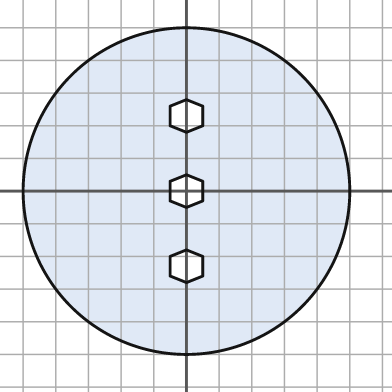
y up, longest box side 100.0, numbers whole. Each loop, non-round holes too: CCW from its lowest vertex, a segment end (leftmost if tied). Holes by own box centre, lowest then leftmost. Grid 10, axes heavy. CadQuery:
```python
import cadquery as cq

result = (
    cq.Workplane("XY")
    .moveTo(0.0, 0.0)
    .circle(50.0)
    .moveTo(0.0, -28.0)
    .lineTo(5.0, -26.0)
    .lineTo(5.0, -20.0)
    .lineTo(0.0, -18.0)
    .lineTo(-5.0, -20.0)
    .lineTo(-5.0, -26.0)
    .close()
    .moveTo(0.0, -5.0)
    .lineTo(5.0, -3.0)
    .lineTo(5.0, 3.0)
    .lineTo(0.0, 5.0)
    .lineTo(-5.0, 3.0)
    .lineTo(-5.0, -3.0)
    .close()
    .moveTo(0.0, 18.0)
    .lineTo(5.0, 20.0)
    .lineTo(5.0, 26.0)
    .lineTo(0.0, 28.0)
    .lineTo(-5.0, 26.0)
    .lineTo(-5.0, 20.0)
    .close()
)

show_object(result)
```